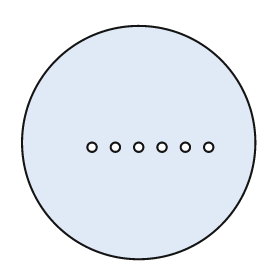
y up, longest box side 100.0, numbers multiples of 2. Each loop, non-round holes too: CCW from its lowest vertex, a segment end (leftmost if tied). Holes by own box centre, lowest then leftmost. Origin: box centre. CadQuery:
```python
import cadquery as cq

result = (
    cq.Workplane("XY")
    .moveTo(0.0, 0.0)
    .circle(50.0)
    .moveTo(-20.0, -2.0)
    .circle(2.0)
    .moveTo(-10.0, -2.0)
    .circle(2.0)
    .moveTo(0.0, -2.0)
    .circle(2.0)
    .moveTo(10.0, -2.0)
    .circle(2.0)
    .moveTo(20.0, -2.0)
    .circle(2.0)
    .moveTo(30.0, -2.0)
    .circle(2.0)
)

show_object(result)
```